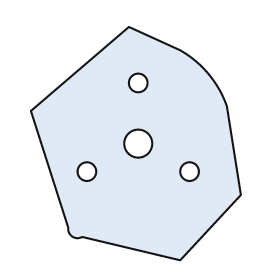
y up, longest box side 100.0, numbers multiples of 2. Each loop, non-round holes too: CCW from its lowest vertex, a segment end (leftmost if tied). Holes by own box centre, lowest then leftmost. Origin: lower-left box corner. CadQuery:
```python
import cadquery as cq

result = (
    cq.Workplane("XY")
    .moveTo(64.0, 0.0)
    .lineTo(90.0, 28.0)
    .lineTo(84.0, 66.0)
    .threePointArc((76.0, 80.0), (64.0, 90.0))
    .lineTo(42.0, 100.0)
    .lineTo(0.0, 64.0)
    .lineTo(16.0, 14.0)
    .threePointArc((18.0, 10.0), (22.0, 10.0))
    .close()
    .moveTo(24.0, 38.0)
    .circle(4.0)
    .moveTo(68.0, 38.0)
    .circle(4.0)
    .moveTo(46.0, 50.0)
    .circle(6.0)
    .moveTo(46.0, 76.0)
    .circle(4.0)
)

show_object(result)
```